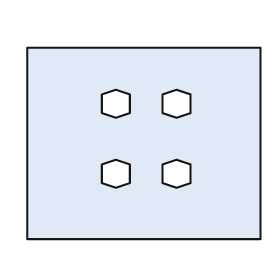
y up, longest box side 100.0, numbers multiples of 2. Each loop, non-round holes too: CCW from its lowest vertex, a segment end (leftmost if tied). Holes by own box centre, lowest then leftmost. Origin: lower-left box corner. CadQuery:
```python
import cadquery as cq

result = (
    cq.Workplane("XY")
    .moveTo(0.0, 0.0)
    .lineTo(100.0, 0.0)
    .lineTo(100.0, 82.0)
    .lineTo(0.0, 82.0)
    .close()
    .moveTo(38.0, 22.0)
    .lineTo(44.0, 24.0)
    .lineTo(44.0, 32.0)
    .lineTo(38.0, 34.0)
    .lineTo(32.0, 32.0)
    .lineTo(32.0, 24.0)
    .close()
    .moveTo(64.0, 22.0)
    .lineTo(70.0, 24.0)
    .lineTo(70.0, 32.0)
    .lineTo(64.0, 34.0)
    .lineTo(58.0, 32.0)
    .lineTo(58.0, 24.0)
    .close()
    .moveTo(38.0, 52.0)
    .lineTo(44.0, 54.0)
    .lineTo(44.0, 62.0)
    .lineTo(38.0, 64.0)
    .lineTo(32.0, 62.0)
    .lineTo(32.0, 54.0)
    .close()
    .moveTo(64.0, 52.0)
    .lineTo(70.0, 54.0)
    .lineTo(70.0, 62.0)
    .lineTo(64.0, 64.0)
    .lineTo(58.0, 62.0)
    .lineTo(58.0, 54.0)
    .close()
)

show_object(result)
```